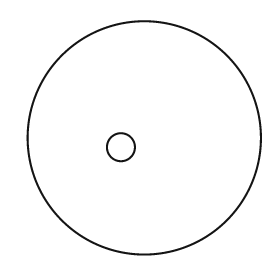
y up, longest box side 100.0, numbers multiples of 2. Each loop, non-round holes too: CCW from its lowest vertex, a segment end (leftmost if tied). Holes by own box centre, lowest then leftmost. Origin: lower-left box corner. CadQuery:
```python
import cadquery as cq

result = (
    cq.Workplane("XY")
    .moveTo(50.0, 50.0)
    .circle(50.0)
    .moveTo(40.0, 46.0)
    .circle(6.0)
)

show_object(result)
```